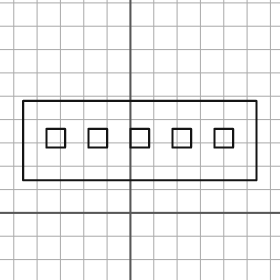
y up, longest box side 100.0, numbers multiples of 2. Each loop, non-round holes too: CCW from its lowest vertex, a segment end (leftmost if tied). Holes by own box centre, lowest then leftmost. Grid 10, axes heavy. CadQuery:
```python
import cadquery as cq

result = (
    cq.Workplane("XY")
    .moveTo(-46.0, 14.0)
    .lineTo(54.0, 14.0)
    .lineTo(54.0, 48.0)
    .lineTo(-46.0, 48.0)
    .close()
    .moveTo(-36.0, 28.0)
    .lineTo(-28.0, 28.0)
    .lineTo(-28.0, 36.0)
    .lineTo(-36.0, 36.0)
    .close()
    .moveTo(-18.0, 28.0)
    .lineTo(-10.0, 28.0)
    .lineTo(-10.0, 36.0)
    .lineTo(-18.0, 36.0)
    .close()
    .moveTo(0.0, 28.0)
    .lineTo(8.0, 28.0)
    .lineTo(8.0, 36.0)
    .lineTo(0.0, 36.0)
    .close()
    .moveTo(18.0, 28.0)
    .lineTo(26.0, 28.0)
    .lineTo(26.0, 36.0)
    .lineTo(18.0, 36.0)
    .close()
    .moveTo(36.0, 28.0)
    .lineTo(44.0, 28.0)
    .lineTo(44.0, 36.0)
    .lineTo(36.0, 36.0)
    .close()
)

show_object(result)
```